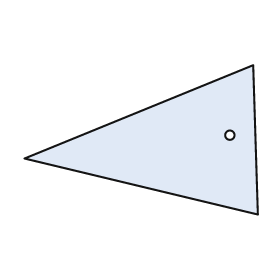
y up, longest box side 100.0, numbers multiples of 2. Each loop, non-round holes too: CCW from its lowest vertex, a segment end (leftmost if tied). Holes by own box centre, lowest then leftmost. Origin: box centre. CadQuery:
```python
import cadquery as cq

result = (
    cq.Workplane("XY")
    .moveTo(50.0, -32.0)
    .lineTo(48.0, 32.0)
    .lineTo(-50.0, -8.0)
    .close()
    .moveTo(38.0, 2.0)
    .circle(2.0)
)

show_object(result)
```